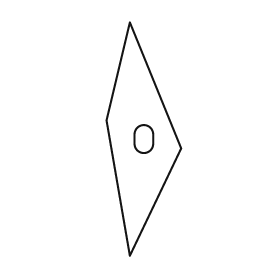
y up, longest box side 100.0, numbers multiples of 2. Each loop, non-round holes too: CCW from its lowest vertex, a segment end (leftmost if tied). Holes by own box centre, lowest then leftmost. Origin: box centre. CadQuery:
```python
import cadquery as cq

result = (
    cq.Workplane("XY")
    .moveTo(-6.0, -50.0)
    .lineTo(16.0, -4.0)
    .lineTo(-6.0, 50.0)
    .lineTo(-16.0, 8.0)
    .close()
    .moveTo(-4.0, -2.0)
    .threePointArc((0.0, -6.0), (4.0, -2.0))
    .lineTo(4.0, 2.0)
    .threePointArc((0.0, 6.0), (-4.0, 2.0))
    .close()
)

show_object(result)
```